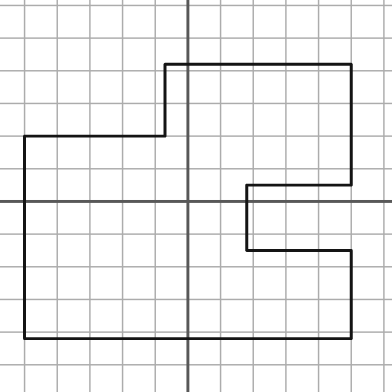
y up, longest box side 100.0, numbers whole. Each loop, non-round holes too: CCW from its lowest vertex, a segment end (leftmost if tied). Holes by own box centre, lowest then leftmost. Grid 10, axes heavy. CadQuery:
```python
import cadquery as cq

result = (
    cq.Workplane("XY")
    .moveTo(-50.0, -42.0)
    .lineTo(50.0, -42.0)
    .lineTo(50.0, -15.0)
    .lineTo(18.0, -15.0)
    .lineTo(18.0, 5.0)
    .lineTo(50.0, 5.0)
    .lineTo(50.0, 42.0)
    .lineTo(-7.0, 42.0)
    .lineTo(-7.0, 20.0)
    .lineTo(-50.0, 20.0)
    .close()
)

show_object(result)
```